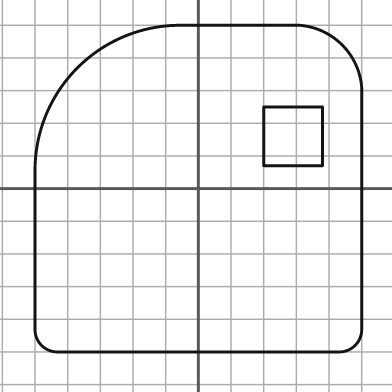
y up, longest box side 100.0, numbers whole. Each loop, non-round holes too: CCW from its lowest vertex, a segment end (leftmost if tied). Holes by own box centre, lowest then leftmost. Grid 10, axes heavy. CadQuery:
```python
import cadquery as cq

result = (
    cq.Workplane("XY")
    .moveTo(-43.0, -50.0)
    .lineTo(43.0, -50.0)
    .threePointArc((48.0, -48.0), (50.0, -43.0))
    .lineTo(50.0, 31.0)
    .threePointArc((44.0, 44.0), (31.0, 50.0))
    .lineTo(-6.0, 50.0)
    .threePointArc((-37.0, 37.0), (-50.0, 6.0))
    .lineTo(-50.0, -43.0)
    .threePointArc((-48.0, -48.0), (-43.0, -50.0))
    .close()
    .moveTo(20.0, 7.0)
    .lineTo(38.0, 7.0)
    .lineTo(38.0, 25.0)
    .lineTo(20.0, 25.0)
    .close()
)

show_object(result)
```